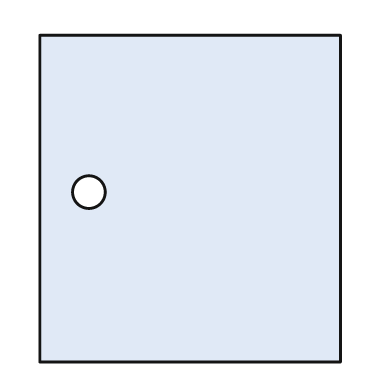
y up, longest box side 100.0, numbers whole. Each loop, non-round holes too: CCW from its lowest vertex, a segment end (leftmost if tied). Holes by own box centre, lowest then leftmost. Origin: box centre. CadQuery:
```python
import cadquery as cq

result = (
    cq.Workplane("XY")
    .moveTo(-46.0, -50.0)
    .lineTo(46.0, -50.0)
    .lineTo(46.0, 50.0)
    .lineTo(-46.0, 50.0)
    .close()
    .moveTo(-31.0, 2.0)
    .circle(5.0)
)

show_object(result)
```